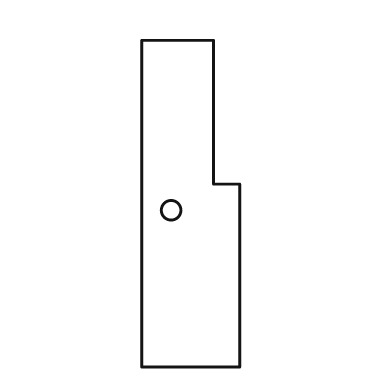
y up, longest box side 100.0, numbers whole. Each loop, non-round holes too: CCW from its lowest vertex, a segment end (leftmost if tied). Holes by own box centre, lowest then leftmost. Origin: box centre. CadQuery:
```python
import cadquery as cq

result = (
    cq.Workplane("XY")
    .moveTo(-15.0, -50.0)
    .lineTo(15.0, -50.0)
    .lineTo(15.0, 6.0)
    .lineTo(7.0, 6.0)
    .lineTo(7.0, 50.0)
    .lineTo(-15.0, 50.0)
    .close()
    .moveTo(-6.0, -2.0)
    .circle(3.0)
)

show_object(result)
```